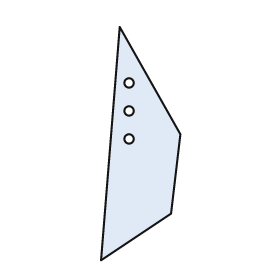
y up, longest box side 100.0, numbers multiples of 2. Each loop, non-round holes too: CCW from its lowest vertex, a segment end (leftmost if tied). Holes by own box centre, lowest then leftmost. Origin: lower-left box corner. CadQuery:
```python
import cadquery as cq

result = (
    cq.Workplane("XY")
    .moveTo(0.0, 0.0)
    .lineTo(30.0, 20.0)
    .lineTo(34.0, 54.0)
    .lineTo(8.0, 100.0)
    .close()
    .moveTo(12.0, 52.0)
    .circle(2.0)
    .moveTo(12.0, 64.0)
    .circle(2.0)
    .moveTo(12.0, 76.0)
    .circle(2.0)
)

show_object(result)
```